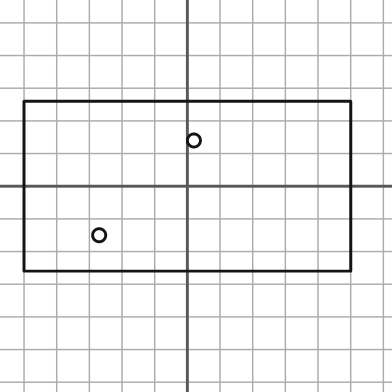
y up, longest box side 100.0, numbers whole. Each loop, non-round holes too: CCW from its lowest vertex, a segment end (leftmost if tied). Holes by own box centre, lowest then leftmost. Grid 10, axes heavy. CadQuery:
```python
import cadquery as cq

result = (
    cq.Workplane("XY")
    .moveTo(-50.0, -26.0)
    .lineTo(50.0, -26.0)
    .lineTo(50.0, 26.0)
    .lineTo(-50.0, 26.0)
    .close()
    .moveTo(-27.0, -15.0)
    .circle(2.0)
    .moveTo(2.0, 14.0)
    .circle(2.0)
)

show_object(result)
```